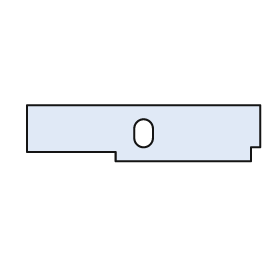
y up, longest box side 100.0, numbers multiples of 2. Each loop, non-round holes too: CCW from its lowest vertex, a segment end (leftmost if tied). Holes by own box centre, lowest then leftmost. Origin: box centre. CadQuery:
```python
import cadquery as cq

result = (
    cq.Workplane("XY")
    .moveTo(-12.0, -12.0)
    .lineTo(46.0, -12.0)
    .lineTo(46.0, -6.0)
    .lineTo(50.0, -6.0)
    .lineTo(50.0, 12.0)
    .lineTo(-50.0, 12.0)
    .lineTo(-50.0, -8.0)
    .lineTo(-12.0, -8.0)
    .close()
    .moveTo(-4.0, -2.0)
    .threePointArc((0.0, -6.0), (4.0, -2.0))
    .lineTo(4.0, 2.0)
    .threePointArc((0.0, 6.0), (-4.0, 2.0))
    .close()
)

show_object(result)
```